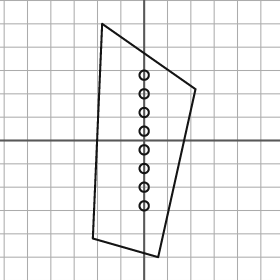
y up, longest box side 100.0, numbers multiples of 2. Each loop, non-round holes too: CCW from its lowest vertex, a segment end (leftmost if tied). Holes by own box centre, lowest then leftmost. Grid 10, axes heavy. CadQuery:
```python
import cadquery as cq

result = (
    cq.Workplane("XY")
    .moveTo(6.0, -50.0)
    .lineTo(22.0, 22.0)
    .lineTo(-18.0, 50.0)
    .lineTo(-22.0, -42.0)
    .close()
    .moveTo(0.0, -28.0)
    .circle(2.0)
    .moveTo(0.0, -20.0)
    .circle(2.0)
    .moveTo(0.0, -12.0)
    .circle(2.0)
    .moveTo(0.0, -4.0)
    .circle(2.0)
    .moveTo(0.0, 4.0)
    .circle(2.0)
    .moveTo(0.0, 12.0)
    .circle(2.0)
    .moveTo(0.0, 20.0)
    .circle(2.0)
    .moveTo(0.0, 28.0)
    .circle(2.0)
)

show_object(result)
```